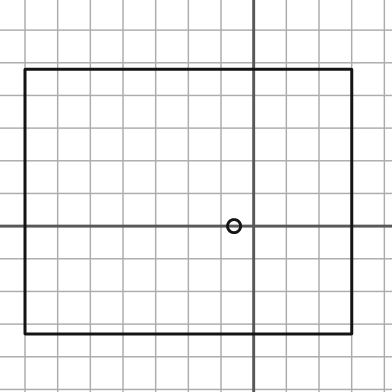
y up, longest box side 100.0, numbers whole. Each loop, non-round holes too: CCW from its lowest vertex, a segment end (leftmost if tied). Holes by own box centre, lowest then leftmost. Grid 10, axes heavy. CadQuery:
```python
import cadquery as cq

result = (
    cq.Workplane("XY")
    .moveTo(-70.0, -33.0)
    .lineTo(30.0, -33.0)
    .lineTo(30.0, 48.0)
    .lineTo(-70.0, 48.0)
    .close()
    .moveTo(-6.0, 0.0)
    .circle(2.0)
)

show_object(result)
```